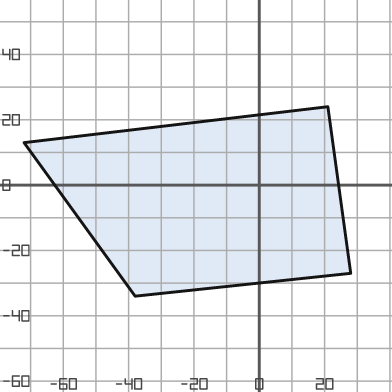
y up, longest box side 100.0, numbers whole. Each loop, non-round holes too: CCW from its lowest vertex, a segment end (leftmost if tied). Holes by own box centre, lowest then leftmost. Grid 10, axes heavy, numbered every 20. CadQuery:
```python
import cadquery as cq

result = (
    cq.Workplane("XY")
    .moveTo(-38.0, -34.0)
    .lineTo(28.0, -27.0)
    .lineTo(21.0, 24.0)
    .lineTo(-72.0, 13.0)
    .close()
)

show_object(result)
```